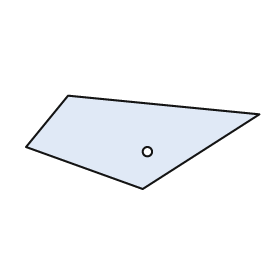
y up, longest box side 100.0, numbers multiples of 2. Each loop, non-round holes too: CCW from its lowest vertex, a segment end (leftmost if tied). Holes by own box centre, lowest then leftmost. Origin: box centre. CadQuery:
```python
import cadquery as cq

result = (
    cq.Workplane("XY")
    .moveTo(0.0, -20.0)
    .lineTo(50.0, 12.0)
    .lineTo(-32.0, 20.0)
    .lineTo(-50.0, -2.0)
    .close()
    .moveTo(2.0, -4.0)
    .circle(2.0)
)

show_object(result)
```